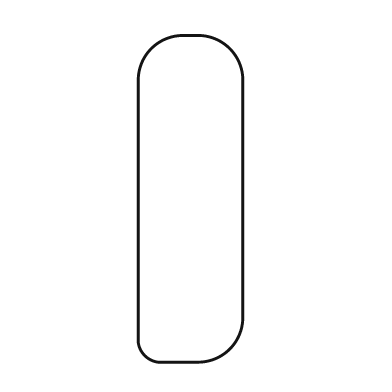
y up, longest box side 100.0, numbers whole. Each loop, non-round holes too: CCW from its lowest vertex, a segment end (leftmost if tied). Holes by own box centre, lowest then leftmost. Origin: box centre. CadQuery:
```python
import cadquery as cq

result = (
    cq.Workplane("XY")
    .moveTo(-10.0, -50.0)
    .lineTo(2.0, -50.0)
    .threePointArc((12.0, -46.0), (16.0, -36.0))
    .lineTo(16.0, 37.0)
    .threePointArc((12.0, 46.0), (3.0, 50.0))
    .lineTo(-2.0, 50.0)
    .threePointArc((-12.0, 46.0), (-16.0, 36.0))
    .lineTo(-16.0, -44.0)
    .threePointArc((-14.0, -48.0), (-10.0, -50.0))
    .close()
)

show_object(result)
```